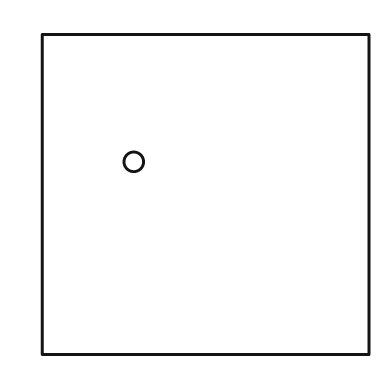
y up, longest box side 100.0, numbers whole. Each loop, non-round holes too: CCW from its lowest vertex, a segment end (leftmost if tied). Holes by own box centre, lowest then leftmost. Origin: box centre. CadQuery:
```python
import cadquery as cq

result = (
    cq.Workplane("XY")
    .moveTo(-50.0, -49.0)
    .lineTo(50.0, -49.0)
    .lineTo(50.0, 49.0)
    .lineTo(-50.0, 49.0)
    .close()
    .moveTo(-22.0, 10.0)
    .circle(3.0)
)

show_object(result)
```